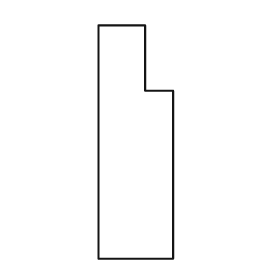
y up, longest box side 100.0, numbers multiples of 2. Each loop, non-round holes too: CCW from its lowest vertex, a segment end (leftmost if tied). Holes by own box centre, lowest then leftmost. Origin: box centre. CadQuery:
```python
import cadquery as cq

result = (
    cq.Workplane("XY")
    .moveTo(-16.0, -50.0)
    .lineTo(16.0, -50.0)
    .lineTo(16.0, 22.0)
    .lineTo(4.0, 22.0)
    .lineTo(4.0, 50.0)
    .lineTo(-16.0, 50.0)
    .close()
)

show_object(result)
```